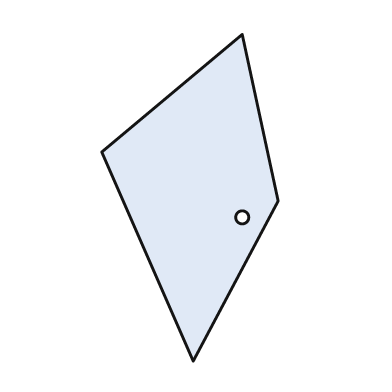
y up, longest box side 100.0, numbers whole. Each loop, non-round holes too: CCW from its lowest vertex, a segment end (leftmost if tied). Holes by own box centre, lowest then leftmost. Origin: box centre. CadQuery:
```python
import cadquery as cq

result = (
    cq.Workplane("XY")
    .moveTo(1.0, -50.0)
    .lineTo(27.0, -1.0)
    .lineTo(16.0, 50.0)
    .lineTo(-27.0, 14.0)
    .close()
    .moveTo(16.0, -6.0)
    .circle(2.0)
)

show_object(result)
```